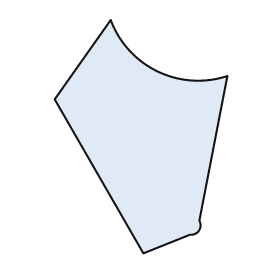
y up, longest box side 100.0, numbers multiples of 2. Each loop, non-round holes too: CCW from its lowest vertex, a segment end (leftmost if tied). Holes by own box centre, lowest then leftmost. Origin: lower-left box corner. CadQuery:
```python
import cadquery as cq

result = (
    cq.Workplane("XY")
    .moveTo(38.0, 0.0)
    .lineTo(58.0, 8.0)
    .threePointArc((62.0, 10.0), (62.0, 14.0))
    .lineTo(74.0, 76.0)
    .threePointArc((44.0, 78.0), (24.0, 100.0))
    .lineTo(0.0, 66.0)
    .close()
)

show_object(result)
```